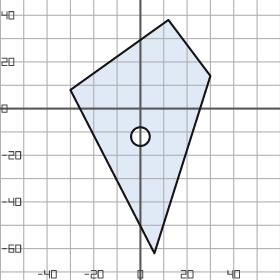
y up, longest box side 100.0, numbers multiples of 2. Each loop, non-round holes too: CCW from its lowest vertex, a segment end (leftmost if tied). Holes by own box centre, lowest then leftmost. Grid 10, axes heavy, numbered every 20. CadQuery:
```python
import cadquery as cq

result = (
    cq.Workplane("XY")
    .moveTo(6.0, -62.0)
    .lineTo(30.0, 14.0)
    .lineTo(12.0, 38.0)
    .lineTo(-30.0, 8.0)
    .close()
    .moveTo(0.0, -12.0)
    .circle(4.0)
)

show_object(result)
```